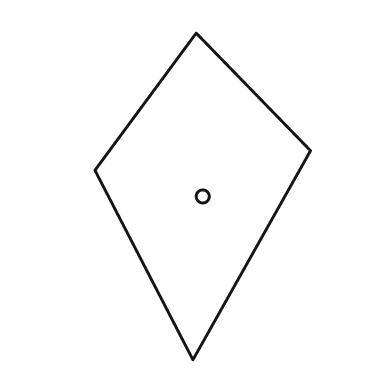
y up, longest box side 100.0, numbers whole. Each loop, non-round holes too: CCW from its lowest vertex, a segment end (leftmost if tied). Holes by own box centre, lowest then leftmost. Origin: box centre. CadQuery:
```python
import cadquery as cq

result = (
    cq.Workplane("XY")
    .moveTo(-3.0, -50.0)
    .lineTo(33.0, 14.0)
    .lineTo(-2.0, 50.0)
    .lineTo(-33.0, 8.0)
    .close()
    .moveTo(0.0, 0.0)
    .circle(2.0)
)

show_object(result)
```